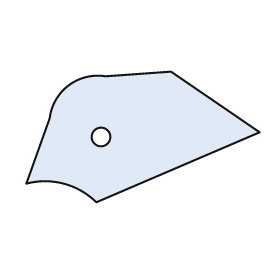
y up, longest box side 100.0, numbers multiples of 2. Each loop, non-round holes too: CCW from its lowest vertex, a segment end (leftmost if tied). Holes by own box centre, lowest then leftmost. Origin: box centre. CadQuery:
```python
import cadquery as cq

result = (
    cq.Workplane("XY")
    .moveTo(-20.0, -28.0)
    .lineTo(50.0, 2.0)
    .lineTo(12.0, 28.0)
    .lineTo(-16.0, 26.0)
    .threePointArc((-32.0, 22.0), (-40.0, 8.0))
    .lineTo(-50.0, -20.0)
    .threePointArc((-34.0, -20.0), (-20.0, -28.0))
    .close()
    .moveTo(-18.0, 0.0)
    .circle(4.0)
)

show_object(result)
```